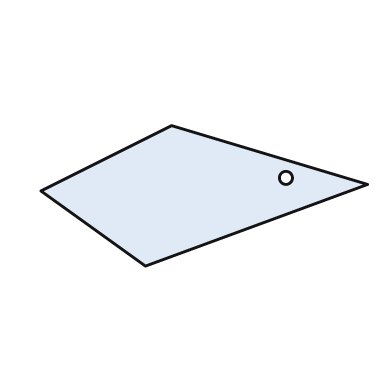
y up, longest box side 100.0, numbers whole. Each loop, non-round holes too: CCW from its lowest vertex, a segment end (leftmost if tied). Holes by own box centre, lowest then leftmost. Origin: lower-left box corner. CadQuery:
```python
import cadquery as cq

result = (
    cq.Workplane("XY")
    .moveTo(32.0, 0.0)
    .lineTo(100.0, 25.0)
    .lineTo(40.0, 43.0)
    .lineTo(0.0, 23.0)
    .close()
    .moveTo(75.0, 27.0)
    .circle(2.0)
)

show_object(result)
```